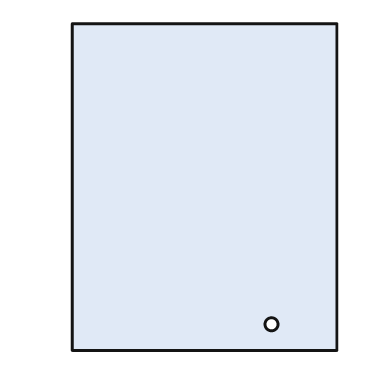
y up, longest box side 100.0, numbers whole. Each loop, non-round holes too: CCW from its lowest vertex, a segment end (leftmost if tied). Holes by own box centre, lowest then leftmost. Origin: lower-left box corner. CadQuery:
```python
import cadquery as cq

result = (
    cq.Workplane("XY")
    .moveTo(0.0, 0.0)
    .lineTo(81.0, 0.0)
    .lineTo(81.0, 100.0)
    .lineTo(0.0, 100.0)
    .close()
    .moveTo(61.0, 8.0)
    .circle(2.0)
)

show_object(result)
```